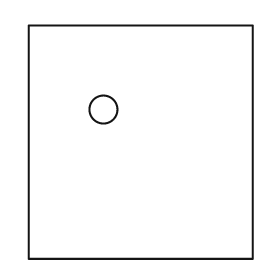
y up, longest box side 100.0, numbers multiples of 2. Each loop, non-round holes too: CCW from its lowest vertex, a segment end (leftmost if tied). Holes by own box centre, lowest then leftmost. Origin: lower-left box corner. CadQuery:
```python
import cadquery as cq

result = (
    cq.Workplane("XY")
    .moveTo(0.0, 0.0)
    .lineTo(96.0, 0.0)
    .lineTo(96.0, 100.0)
    .lineTo(0.0, 100.0)
    .close()
    .moveTo(32.0, 64.0)
    .circle(6.0)
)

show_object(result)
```